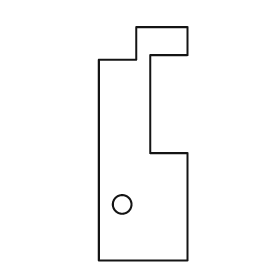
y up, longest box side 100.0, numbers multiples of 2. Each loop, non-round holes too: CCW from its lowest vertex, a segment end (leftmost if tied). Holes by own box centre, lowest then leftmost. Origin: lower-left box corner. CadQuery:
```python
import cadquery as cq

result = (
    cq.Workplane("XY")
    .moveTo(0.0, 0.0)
    .lineTo(38.0, 0.0)
    .lineTo(38.0, 46.0)
    .lineTo(22.0, 46.0)
    .lineTo(22.0, 88.0)
    .lineTo(38.0, 88.0)
    .lineTo(38.0, 100.0)
    .lineTo(16.0, 100.0)
    .lineTo(16.0, 86.0)
    .lineTo(0.0, 86.0)
    .close()
    .moveTo(10.0, 24.0)
    .circle(4.0)
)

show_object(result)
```